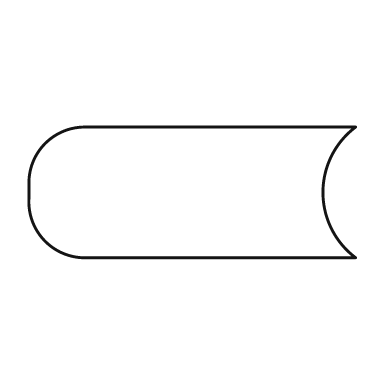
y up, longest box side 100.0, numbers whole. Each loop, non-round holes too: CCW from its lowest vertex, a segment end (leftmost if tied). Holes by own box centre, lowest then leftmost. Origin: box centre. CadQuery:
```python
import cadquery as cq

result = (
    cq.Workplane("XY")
    .moveTo(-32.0, -20.0)
    .lineTo(50.0, -20.0)
    .threePointArc((40.0, 0.0), (50.0, 20.0))
    .lineTo(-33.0, 20.0)
    .threePointArc((-45.0, 15.0), (-50.0, 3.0))
    .lineTo(-50.0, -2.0)
    .threePointArc((-45.0, -15.0), (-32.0, -20.0))
    .close()
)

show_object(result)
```